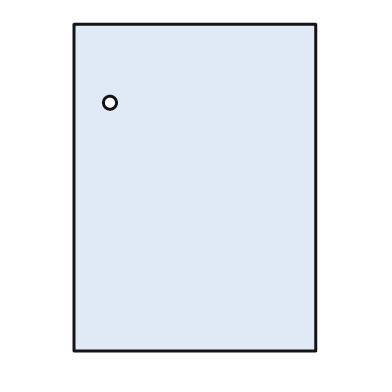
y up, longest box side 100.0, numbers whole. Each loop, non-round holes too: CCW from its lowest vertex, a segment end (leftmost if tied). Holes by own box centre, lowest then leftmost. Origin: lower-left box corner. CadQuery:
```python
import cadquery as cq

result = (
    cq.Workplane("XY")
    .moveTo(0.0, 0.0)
    .lineTo(74.0, 0.0)
    .lineTo(74.0, 100.0)
    .lineTo(0.0, 100.0)
    .close()
    .moveTo(11.0, 76.0)
    .circle(2.0)
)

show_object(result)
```